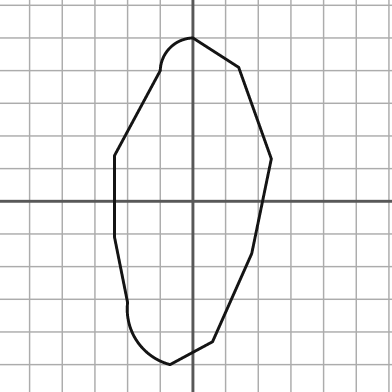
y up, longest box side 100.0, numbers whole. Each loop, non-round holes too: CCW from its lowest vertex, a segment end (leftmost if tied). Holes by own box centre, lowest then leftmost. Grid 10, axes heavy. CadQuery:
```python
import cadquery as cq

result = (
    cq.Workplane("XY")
    .moveTo(-7.0, -50.0)
    .lineTo(6.0, -43.0)
    .lineTo(18.0, -16.0)
    .lineTo(24.0, 13.0)
    .lineTo(14.0, 41.0)
    .lineTo(0.0, 50.0)
    .threePointArc((-7.0, 47.0), (-10.0, 40.0))
    .lineTo(-24.0, 14.0)
    .lineTo(-24.0, -11.0)
    .lineTo(-20.0, -31.0)
    .threePointArc((-17.0, -43.0), (-7.0, -50.0))
    .close()
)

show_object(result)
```